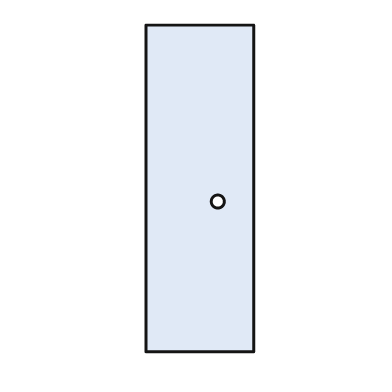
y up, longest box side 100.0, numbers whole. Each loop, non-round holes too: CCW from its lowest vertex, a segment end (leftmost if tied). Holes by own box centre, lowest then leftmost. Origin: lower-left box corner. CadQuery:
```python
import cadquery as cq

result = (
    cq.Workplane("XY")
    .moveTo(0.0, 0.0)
    .lineTo(33.0, 0.0)
    .lineTo(33.0, 100.0)
    .lineTo(0.0, 100.0)
    .close()
    .moveTo(22.0, 46.0)
    .circle(2.0)
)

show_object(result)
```